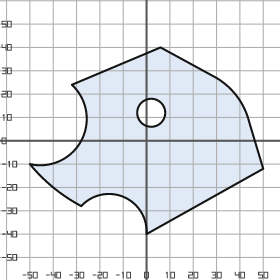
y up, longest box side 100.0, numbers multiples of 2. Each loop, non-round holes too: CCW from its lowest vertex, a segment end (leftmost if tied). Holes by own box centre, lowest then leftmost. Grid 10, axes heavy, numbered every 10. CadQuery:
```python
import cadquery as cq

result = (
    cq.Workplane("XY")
    .moveTo(0.0, -40.0)
    .lineTo(50.0, -12.0)
    .lineTo(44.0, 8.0)
    .threePointArc((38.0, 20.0), (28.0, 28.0))
    .lineTo(6.0, 40.0)
    .lineTo(-32.0, 24.0)
    .threePointArc((-28.0, 0.0), (-50.0, -10.0))
    .threePointArc((-40.0, -20.0), (-28.0, -28.0))
    .threePointArc((-10.0, -24.0), (0.0, -40.0))
    .close()
    .moveTo(2.0, 12.0)
    .circle(6.0)
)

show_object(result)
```